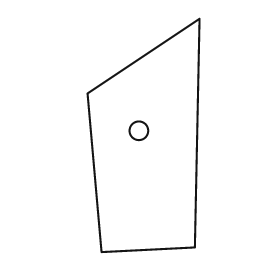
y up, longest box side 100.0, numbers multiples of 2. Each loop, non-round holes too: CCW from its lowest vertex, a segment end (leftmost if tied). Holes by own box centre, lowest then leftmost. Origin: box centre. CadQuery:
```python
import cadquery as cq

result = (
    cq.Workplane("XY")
    .moveTo(-18.0, -50.0)
    .lineTo(22.0, -48.0)
    .lineTo(24.0, 50.0)
    .lineTo(-24.0, 18.0)
    .close()
    .moveTo(-2.0, 2.0)
    .circle(4.0)
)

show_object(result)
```